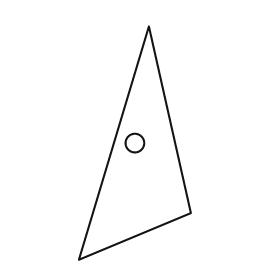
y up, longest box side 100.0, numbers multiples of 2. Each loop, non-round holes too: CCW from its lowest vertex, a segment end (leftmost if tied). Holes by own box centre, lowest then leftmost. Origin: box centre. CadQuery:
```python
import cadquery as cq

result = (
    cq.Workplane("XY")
    .moveTo(-24.0, -50.0)
    .lineTo(24.0, -30.0)
    .lineTo(6.0, 50.0)
    .close()
    .moveTo(0.0, 0.0)
    .circle(4.0)
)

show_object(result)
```